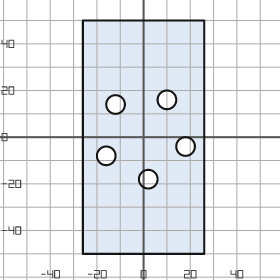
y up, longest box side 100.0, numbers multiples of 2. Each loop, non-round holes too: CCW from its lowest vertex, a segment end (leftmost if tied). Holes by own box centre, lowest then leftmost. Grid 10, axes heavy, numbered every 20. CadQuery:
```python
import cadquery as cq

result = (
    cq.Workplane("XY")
    .moveTo(-26.0, -50.0)
    .lineTo(26.0, -50.0)
    .lineTo(26.0, 50.0)
    .lineTo(-26.0, 50.0)
    .close()
    .moveTo(2.0, -18.0)
    .circle(4.0)
    .moveTo(-16.0, -8.0)
    .circle(4.0)
    .moveTo(18.0, -4.0)
    .circle(4.0)
    .moveTo(-12.0, 14.0)
    .circle(4.0)
    .moveTo(10.0, 16.0)
    .circle(4.0)
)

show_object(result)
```